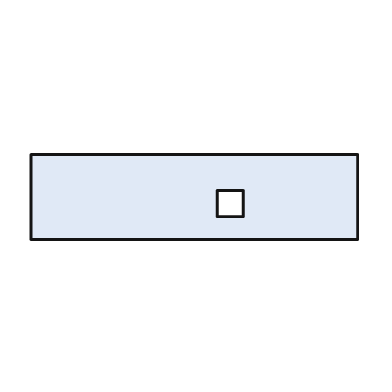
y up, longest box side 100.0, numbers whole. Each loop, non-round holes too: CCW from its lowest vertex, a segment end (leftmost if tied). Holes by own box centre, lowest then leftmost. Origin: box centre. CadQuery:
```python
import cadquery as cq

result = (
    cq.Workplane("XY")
    .moveTo(-50.0, -13.0)
    .lineTo(50.0, -13.0)
    .lineTo(50.0, 13.0)
    .lineTo(-50.0, 13.0)
    .close()
    .moveTo(7.0, -6.0)
    .lineTo(15.0, -6.0)
    .lineTo(15.0, 2.0)
    .lineTo(7.0, 2.0)
    .close()
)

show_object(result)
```